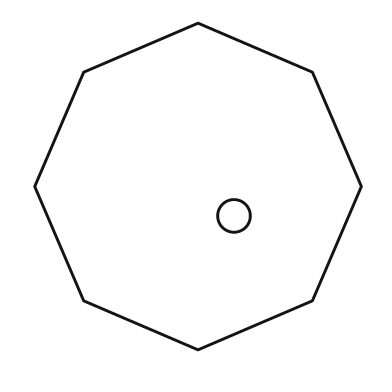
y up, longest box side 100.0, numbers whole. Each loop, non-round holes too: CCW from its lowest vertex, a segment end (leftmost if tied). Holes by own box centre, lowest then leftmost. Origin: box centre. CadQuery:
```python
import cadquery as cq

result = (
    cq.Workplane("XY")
    .moveTo(0.0, -50.0)
    .lineTo(35.0, -35.0)
    .lineTo(50.0, 0.0)
    .lineTo(35.0, 35.0)
    .lineTo(0.0, 50.0)
    .lineTo(-35.0, 35.0)
    .lineTo(-50.0, 0.0)
    .lineTo(-35.0, -35.0)
    .close()
    .moveTo(11.0, -9.0)
    .circle(5.0)
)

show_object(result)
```